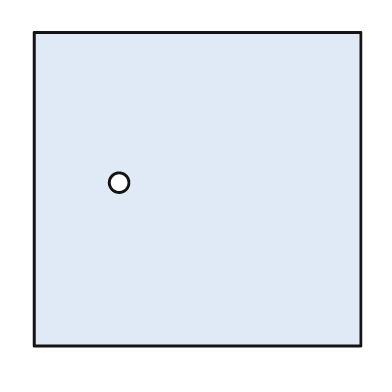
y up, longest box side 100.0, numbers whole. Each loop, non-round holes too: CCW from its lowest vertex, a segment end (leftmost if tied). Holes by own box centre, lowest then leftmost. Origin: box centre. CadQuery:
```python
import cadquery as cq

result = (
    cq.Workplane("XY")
    .moveTo(-50.0, -48.0)
    .lineTo(50.0, -48.0)
    .lineTo(50.0, 48.0)
    .lineTo(-50.0, 48.0)
    .close()
    .moveTo(-24.0, 2.0)
    .circle(3.0)
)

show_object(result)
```